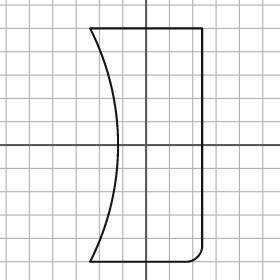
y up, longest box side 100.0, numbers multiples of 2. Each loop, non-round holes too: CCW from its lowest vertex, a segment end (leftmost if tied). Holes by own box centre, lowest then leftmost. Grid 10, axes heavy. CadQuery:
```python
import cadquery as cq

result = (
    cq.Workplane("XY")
    .moveTo(-24.0, -50.0)
    .lineTo(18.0, -50.0)
    .threePointArc((22.0, -48.0), (24.0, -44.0))
    .lineTo(24.0, 50.0)
    .lineTo(-24.0, 50.0)
    .threePointArc((-12.0, 0.0), (-24.0, -50.0))
    .close()
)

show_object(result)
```